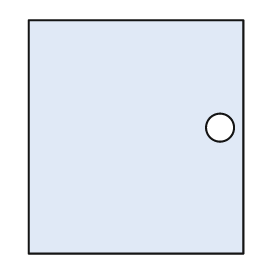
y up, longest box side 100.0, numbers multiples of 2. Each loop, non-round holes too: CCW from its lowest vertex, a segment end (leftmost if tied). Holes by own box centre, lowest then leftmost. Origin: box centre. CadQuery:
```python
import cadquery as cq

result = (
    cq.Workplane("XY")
    .moveTo(-46.0, -50.0)
    .lineTo(46.0, -50.0)
    .lineTo(46.0, 50.0)
    .lineTo(-46.0, 50.0)
    .close()
    .moveTo(36.0, 4.0)
    .circle(6.0)
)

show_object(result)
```